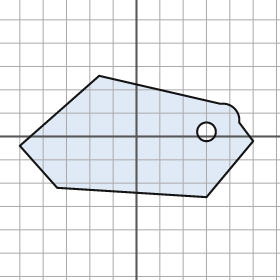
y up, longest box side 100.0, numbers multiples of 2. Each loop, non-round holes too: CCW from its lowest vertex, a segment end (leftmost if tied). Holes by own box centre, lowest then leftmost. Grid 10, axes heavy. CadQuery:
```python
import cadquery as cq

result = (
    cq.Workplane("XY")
    .moveTo(30.0, -26.0)
    .lineTo(50.0, -2.0)
    .lineTo(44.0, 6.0)
    .threePointArc((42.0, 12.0), (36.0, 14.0))
    .lineTo(-16.0, 26.0)
    .lineTo(-50.0, -4.0)
    .lineTo(-34.0, -22.0)
    .close()
    .moveTo(30.0, 2.0)
    .circle(4.0)
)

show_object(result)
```